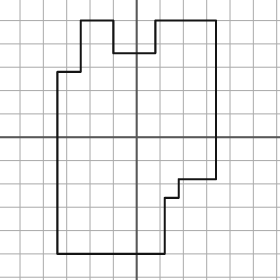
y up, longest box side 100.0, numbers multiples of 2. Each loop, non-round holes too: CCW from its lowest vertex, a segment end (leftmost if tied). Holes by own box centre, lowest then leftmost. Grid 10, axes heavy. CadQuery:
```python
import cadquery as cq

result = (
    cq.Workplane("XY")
    .moveTo(-34.0, -50.0)
    .lineTo(12.0, -50.0)
    .lineTo(12.0, -26.0)
    .lineTo(18.0, -26.0)
    .lineTo(18.0, -18.0)
    .lineTo(34.0, -18.0)
    .lineTo(34.0, 50.0)
    .lineTo(8.0, 50.0)
    .lineTo(8.0, 36.0)
    .lineTo(-10.0, 36.0)
    .lineTo(-10.0, 50.0)
    .lineTo(-24.0, 50.0)
    .lineTo(-24.0, 28.0)
    .lineTo(-34.0, 28.0)
    .close()
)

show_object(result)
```